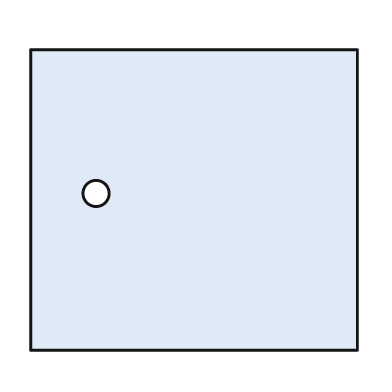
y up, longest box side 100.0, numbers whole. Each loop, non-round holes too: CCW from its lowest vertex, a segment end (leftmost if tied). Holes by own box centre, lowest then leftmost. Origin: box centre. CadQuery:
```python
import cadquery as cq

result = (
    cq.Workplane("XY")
    .moveTo(-50.0, -46.0)
    .lineTo(50.0, -46.0)
    .lineTo(50.0, 46.0)
    .lineTo(-50.0, 46.0)
    .close()
    .moveTo(-30.0, 2.0)
    .circle(4.0)
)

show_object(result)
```